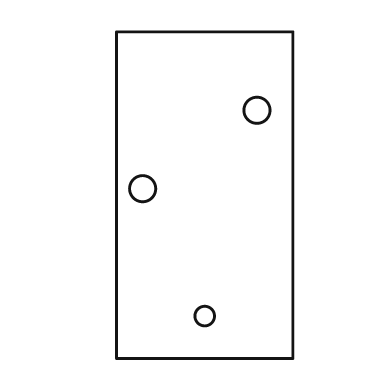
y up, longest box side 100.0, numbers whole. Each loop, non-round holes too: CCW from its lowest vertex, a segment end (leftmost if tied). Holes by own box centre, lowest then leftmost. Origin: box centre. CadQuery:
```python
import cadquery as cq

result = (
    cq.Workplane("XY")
    .moveTo(-27.0, -50.0)
    .lineTo(27.0, -50.0)
    .lineTo(27.0, 50.0)
    .lineTo(-27.0, 50.0)
    .close()
    .moveTo(0.0, -37.0)
    .circle(3.0)
    .moveTo(-19.0, 2.0)
    .circle(4.0)
    .moveTo(16.0, 26.0)
    .circle(4.0)
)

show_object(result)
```